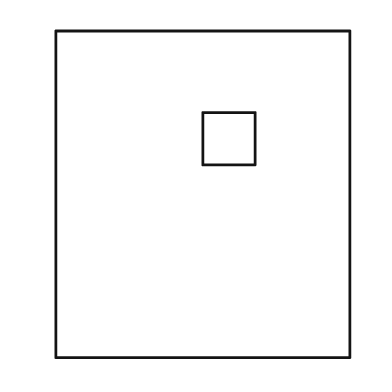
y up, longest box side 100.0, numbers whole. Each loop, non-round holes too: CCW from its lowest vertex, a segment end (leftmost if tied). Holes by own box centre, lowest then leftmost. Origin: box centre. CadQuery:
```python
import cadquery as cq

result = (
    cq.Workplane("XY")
    .moveTo(-45.0, -50.0)
    .lineTo(45.0, -50.0)
    .lineTo(45.0, 50.0)
    .lineTo(-45.0, 50.0)
    .close()
    .moveTo(0.0, 9.0)
    .lineTo(16.0, 9.0)
    .lineTo(16.0, 25.0)
    .lineTo(0.0, 25.0)
    .close()
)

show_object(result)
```